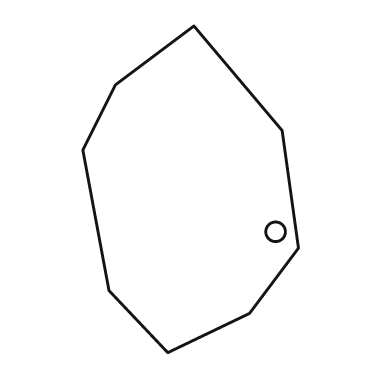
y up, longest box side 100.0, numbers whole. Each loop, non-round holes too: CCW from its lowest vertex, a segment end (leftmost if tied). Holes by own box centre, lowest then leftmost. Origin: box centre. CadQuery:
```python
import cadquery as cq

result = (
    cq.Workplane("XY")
    .moveTo(-7.0, -50.0)
    .lineTo(18.0, -38.0)
    .lineTo(33.0, -18.0)
    .lineTo(28.0, 18.0)
    .lineTo(1.0, 50.0)
    .lineTo(-23.0, 32.0)
    .lineTo(-33.0, 12.0)
    .lineTo(-25.0, -31.0)
    .close()
    .moveTo(26.0, -13.0)
    .circle(3.0)
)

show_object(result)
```